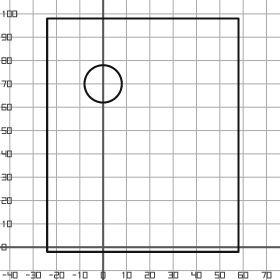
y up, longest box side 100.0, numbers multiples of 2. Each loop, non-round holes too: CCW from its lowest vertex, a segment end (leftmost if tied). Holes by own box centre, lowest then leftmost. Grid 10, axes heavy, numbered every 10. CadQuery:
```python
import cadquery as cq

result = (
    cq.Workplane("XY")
    .moveTo(-24.0, -2.0)
    .lineTo(58.0, -2.0)
    .lineTo(58.0, 98.0)
    .lineTo(-24.0, 98.0)
    .close()
    .moveTo(0.0, 70.0)
    .circle(8.0)
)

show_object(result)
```